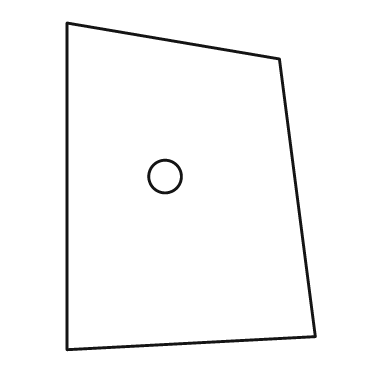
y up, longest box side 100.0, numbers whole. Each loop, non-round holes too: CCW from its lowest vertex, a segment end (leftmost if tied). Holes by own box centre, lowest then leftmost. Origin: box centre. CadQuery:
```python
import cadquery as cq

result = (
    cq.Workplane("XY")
    .moveTo(-38.0, -50.0)
    .lineTo(38.0, -46.0)
    .lineTo(27.0, 39.0)
    .lineTo(-38.0, 50.0)
    .close()
    .moveTo(-8.0, 3.0)
    .circle(5.0)
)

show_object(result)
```